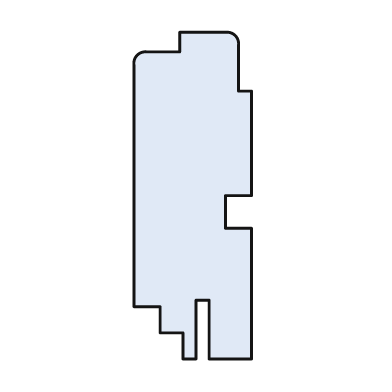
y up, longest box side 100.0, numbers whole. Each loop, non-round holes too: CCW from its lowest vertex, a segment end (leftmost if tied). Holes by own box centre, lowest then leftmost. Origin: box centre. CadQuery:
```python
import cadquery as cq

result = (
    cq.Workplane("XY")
    .moveTo(-3.0, -50.0)
    .lineTo(1.0, -50.0)
    .lineTo(1.0, -32.0)
    .lineTo(5.0, -32.0)
    .lineTo(5.0, -50.0)
    .lineTo(18.0, -50.0)
    .lineTo(18.0, -10.0)
    .lineTo(10.0, -10.0)
    .lineTo(10.0, 0.0)
    .lineTo(18.0, 0.0)
    .lineTo(18.0, 32.0)
    .lineTo(14.0, 32.0)
    .lineTo(14.0, 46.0)
    .threePointArc((13.0, 49.0), (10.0, 50.0))
    .lineTo(-4.0, 50.0)
    .lineTo(-4.0, 44.0)
    .lineTo(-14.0, 44.0)
    .threePointArc((-17.0, 43.0), (-18.0, 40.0))
    .lineTo(-18.0, -34.0)
    .lineTo(-10.0, -34.0)
    .lineTo(-10.0, -42.0)
    .lineTo(-3.0, -42.0)
    .close()
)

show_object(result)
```